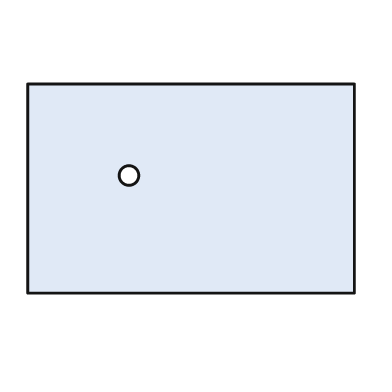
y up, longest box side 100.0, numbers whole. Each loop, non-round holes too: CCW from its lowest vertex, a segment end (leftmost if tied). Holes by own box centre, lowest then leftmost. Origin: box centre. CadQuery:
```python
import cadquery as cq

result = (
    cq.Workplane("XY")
    .moveTo(-50.0, -32.0)
    .lineTo(50.0, -32.0)
    .lineTo(50.0, 32.0)
    .lineTo(-50.0, 32.0)
    .close()
    .moveTo(-19.0, 4.0)
    .circle(3.0)
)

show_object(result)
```